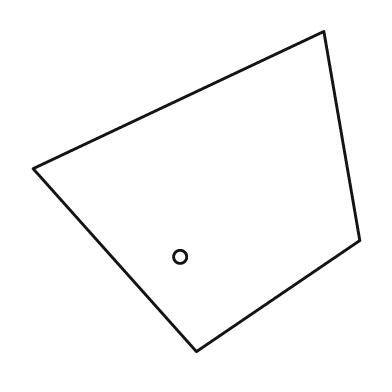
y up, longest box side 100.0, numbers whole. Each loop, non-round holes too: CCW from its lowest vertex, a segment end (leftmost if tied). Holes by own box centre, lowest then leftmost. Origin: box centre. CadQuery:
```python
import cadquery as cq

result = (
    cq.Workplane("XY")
    .moveTo(0.0, -49.0)
    .lineTo(50.0, -15.0)
    .lineTo(39.0, 49.0)
    .lineTo(-50.0, 7.0)
    .close()
    .moveTo(-5.0, -20.0)
    .circle(2.0)
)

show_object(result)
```